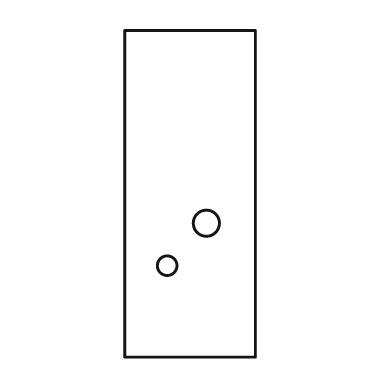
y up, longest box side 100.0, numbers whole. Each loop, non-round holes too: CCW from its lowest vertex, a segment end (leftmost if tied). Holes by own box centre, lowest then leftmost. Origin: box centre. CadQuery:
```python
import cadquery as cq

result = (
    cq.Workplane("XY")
    .moveTo(-20.0, -50.0)
    .lineTo(20.0, -50.0)
    .lineTo(20.0, 50.0)
    .lineTo(-20.0, 50.0)
    .close()
    .moveTo(-7.0, -22.0)
    .circle(3.0)
    .moveTo(5.0, -9.0)
    .circle(4.0)
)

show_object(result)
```